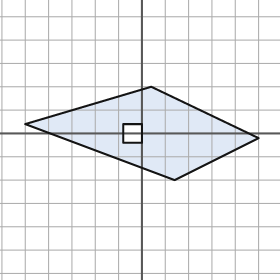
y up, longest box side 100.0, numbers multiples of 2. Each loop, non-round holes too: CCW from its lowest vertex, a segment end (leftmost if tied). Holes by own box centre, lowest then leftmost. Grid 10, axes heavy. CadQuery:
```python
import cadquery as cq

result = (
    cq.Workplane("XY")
    .moveTo(14.0, -20.0)
    .lineTo(50.0, -2.0)
    .lineTo(4.0, 20.0)
    .lineTo(-50.0, 4.0)
    .close()
    .moveTo(-8.0, -4.0)
    .lineTo(0.0, -4.0)
    .lineTo(0.0, 4.0)
    .lineTo(-8.0, 4.0)
    .close()
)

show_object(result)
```